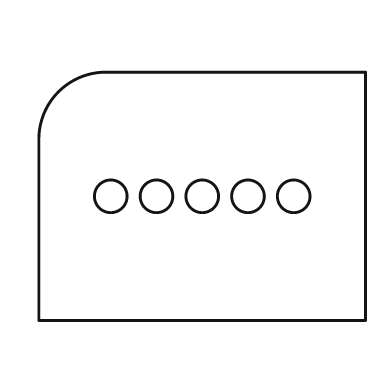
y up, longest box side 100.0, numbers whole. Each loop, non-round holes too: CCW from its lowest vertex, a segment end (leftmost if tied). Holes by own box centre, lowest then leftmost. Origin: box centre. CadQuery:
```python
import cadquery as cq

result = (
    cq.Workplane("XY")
    .moveTo(-50.0, -38.0)
    .lineTo(50.0, -38.0)
    .lineTo(50.0, 38.0)
    .lineTo(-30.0, 38.0)
    .threePointArc((-44.0, 32.0), (-50.0, 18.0))
    .close()
    .moveTo(-28.0, 0.0)
    .circle(5.0)
    .moveTo(-14.0, 0.0)
    .circle(5.0)
    .moveTo(0.0, 0.0)
    .circle(5.0)
    .moveTo(14.0, 0.0)
    .circle(5.0)
    .moveTo(28.0, 0.0)
    .circle(5.0)
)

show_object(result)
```